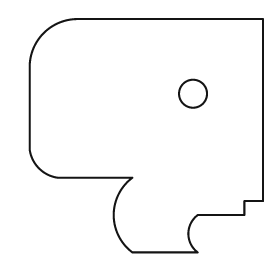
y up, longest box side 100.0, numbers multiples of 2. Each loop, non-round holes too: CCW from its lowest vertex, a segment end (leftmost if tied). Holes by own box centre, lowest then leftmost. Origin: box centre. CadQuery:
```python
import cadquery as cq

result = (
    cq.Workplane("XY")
    .moveTo(-6.0, -50.0)
    .lineTo(22.0, -50.0)
    .threePointArc((18.0, -42.0), (22.0, -34.0))
    .lineTo(42.0, -34.0)
    .lineTo(42.0, -28.0)
    .lineTo(50.0, -28.0)
    .lineTo(50.0, 50.0)
    .lineTo(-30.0, 50.0)
    .threePointArc((-44.0, 44.0), (-50.0, 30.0))
    .lineTo(-50.0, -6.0)
    .threePointArc((-46.0, -14.0), (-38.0, -18.0))
    .lineTo(-6.0, -18.0)
    .threePointArc((-14.0, -34.0), (-6.0, -50.0))
    .close()
    .moveTo(20.0, 18.0)
    .circle(6.0)
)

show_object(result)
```